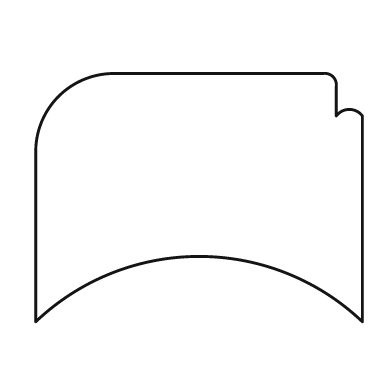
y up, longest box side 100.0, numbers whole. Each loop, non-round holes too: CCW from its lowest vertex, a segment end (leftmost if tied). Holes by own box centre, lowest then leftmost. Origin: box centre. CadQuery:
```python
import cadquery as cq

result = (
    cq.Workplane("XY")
    .moveTo(-50.0, -38.0)
    .threePointArc((0.0, -18.0), (50.0, -38.0))
    .lineTo(50.0, 25.0)
    .threePointArc((46.0, 27.0), (42.0, 25.0))
    .lineTo(42.0, 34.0)
    .threePointArc((41.0, 37.0), (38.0, 38.0))
    .lineTo(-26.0, 38.0)
    .threePointArc((-43.0, 31.0), (-50.0, 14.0))
    .close()
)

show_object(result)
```